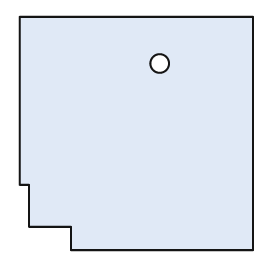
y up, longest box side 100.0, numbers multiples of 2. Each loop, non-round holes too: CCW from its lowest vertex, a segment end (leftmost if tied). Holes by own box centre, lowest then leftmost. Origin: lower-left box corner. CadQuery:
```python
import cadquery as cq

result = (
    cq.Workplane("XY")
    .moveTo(22.0, 0.0)
    .lineTo(100.0, 0.0)
    .lineTo(100.0, 100.0)
    .lineTo(0.0, 100.0)
    .lineTo(0.0, 28.0)
    .lineTo(4.0, 28.0)
    .lineTo(4.0, 10.0)
    .lineTo(22.0, 10.0)
    .close()
    .moveTo(60.0, 80.0)
    .circle(4.0)
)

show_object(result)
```